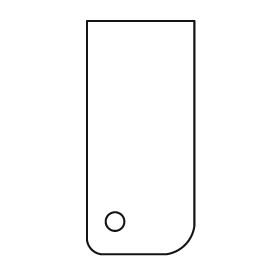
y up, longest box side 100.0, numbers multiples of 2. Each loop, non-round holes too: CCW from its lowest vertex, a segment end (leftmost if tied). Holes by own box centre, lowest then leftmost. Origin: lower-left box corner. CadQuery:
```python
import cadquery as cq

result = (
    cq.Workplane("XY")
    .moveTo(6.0, 0.0)
    .lineTo(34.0, 0.0)
    .threePointArc((42.0, 4.0), (46.0, 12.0))
    .lineTo(46.0, 100.0)
    .lineTo(0.0, 100.0)
    .lineTo(0.0, 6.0)
    .threePointArc((2.0, 2.0), (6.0, 0.0))
    .close()
    .moveTo(12.0, 14.0)
    .circle(4.0)
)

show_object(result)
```